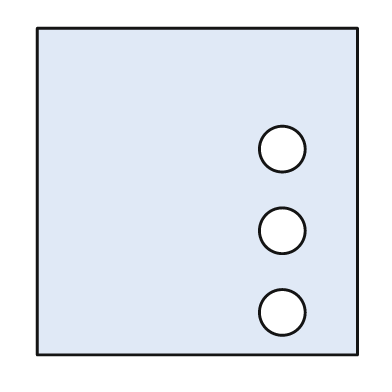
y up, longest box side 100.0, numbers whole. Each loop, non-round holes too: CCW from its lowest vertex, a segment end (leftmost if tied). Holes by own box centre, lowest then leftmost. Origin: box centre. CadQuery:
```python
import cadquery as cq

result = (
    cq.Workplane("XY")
    .moveTo(-49.0, -50.0)
    .lineTo(49.0, -50.0)
    .lineTo(49.0, 50.0)
    .lineTo(-49.0, 50.0)
    .close()
    .moveTo(26.0, -37.0)
    .circle(7.0)
    .moveTo(26.0, -12.0)
    .circle(7.0)
    .moveTo(26.0, 13.0)
    .circle(7.0)
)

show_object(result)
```